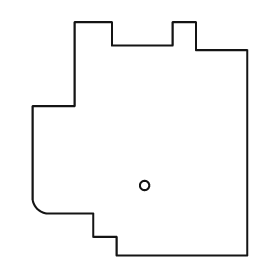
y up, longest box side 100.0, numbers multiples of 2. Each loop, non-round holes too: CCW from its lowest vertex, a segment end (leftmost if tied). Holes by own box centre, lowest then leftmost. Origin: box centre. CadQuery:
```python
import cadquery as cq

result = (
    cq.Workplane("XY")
    .moveTo(-10.0, -50.0)
    .lineTo(46.0, -50.0)
    .lineTo(46.0, 38.0)
    .lineTo(24.0, 38.0)
    .lineTo(24.0, 50.0)
    .lineTo(14.0, 50.0)
    .lineTo(14.0, 40.0)
    .lineTo(-12.0, 40.0)
    .lineTo(-12.0, 50.0)
    .lineTo(-28.0, 50.0)
    .lineTo(-28.0, 14.0)
    .lineTo(-46.0, 14.0)
    .lineTo(-46.0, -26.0)
    .threePointArc((-44.0, -30.0), (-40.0, -32.0))
    .lineTo(-20.0, -32.0)
    .lineTo(-20.0, -42.0)
    .lineTo(-10.0, -42.0)
    .close()
    .moveTo(2.0, -20.0)
    .circle(2.0)
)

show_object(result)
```